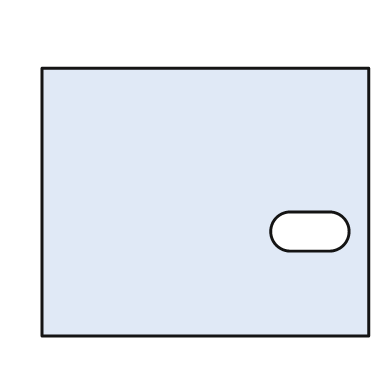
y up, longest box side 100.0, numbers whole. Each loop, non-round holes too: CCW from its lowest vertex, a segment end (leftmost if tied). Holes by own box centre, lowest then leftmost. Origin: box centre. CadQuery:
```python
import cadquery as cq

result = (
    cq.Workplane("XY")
    .moveTo(-50.0, -41.0)
    .lineTo(50.0, -41.0)
    .lineTo(50.0, 41.0)
    .lineTo(-50.0, 41.0)
    .close()
    .moveTo(26.0, -15.0)
    .lineTo(38.0, -15.0)
    .threePointArc((44.0, -9.0), (38.0, -3.0))
    .lineTo(26.0, -3.0)
    .threePointArc((20.0, -9.0), (26.0, -15.0))
    .close()
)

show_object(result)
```